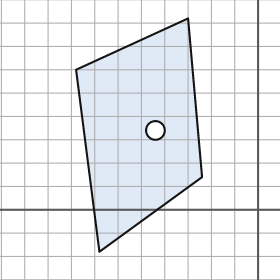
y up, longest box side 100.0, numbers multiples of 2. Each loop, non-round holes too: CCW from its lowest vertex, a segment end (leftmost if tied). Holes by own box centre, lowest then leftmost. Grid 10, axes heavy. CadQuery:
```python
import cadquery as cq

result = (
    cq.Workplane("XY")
    .moveTo(-68.0, -18.0)
    .lineTo(-24.0, 14.0)
    .lineTo(-30.0, 82.0)
    .lineTo(-78.0, 60.0)
    .close()
    .moveTo(-44.0, 34.0)
    .circle(4.0)
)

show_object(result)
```